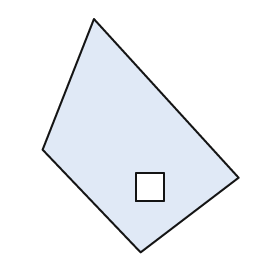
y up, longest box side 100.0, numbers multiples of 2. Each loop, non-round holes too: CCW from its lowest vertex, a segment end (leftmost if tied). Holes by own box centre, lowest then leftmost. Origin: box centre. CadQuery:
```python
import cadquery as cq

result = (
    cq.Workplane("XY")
    .moveTo(0.0, -50.0)
    .lineTo(42.0, -18.0)
    .lineTo(-20.0, 50.0)
    .lineTo(-42.0, -6.0)
    .close()
    .moveTo(-2.0, -28.0)
    .lineTo(10.0, -28.0)
    .lineTo(10.0, -16.0)
    .lineTo(-2.0, -16.0)
    .close()
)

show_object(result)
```